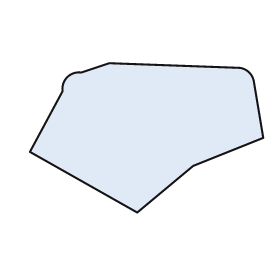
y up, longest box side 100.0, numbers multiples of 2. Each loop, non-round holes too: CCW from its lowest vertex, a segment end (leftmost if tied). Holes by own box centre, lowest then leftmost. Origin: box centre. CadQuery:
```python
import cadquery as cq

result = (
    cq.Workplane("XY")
    .moveTo(-4.0, -32.0)
    .lineTo(20.0, -12.0)
    .lineTo(50.0, 0.0)
    .lineTo(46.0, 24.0)
    .threePointArc((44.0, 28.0), (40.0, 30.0))
    .lineTo(-16.0, 32.0)
    .lineTo(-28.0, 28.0)
    .threePointArc((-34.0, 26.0), (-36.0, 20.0))
    .lineTo(-50.0, -6.0)
    .close()
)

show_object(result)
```